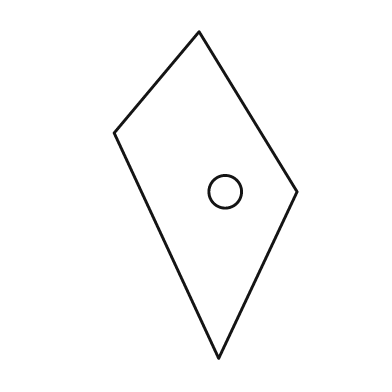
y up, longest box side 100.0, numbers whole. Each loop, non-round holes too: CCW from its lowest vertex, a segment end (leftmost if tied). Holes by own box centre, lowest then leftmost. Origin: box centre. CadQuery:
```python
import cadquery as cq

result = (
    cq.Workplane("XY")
    .moveTo(4.0, -50.0)
    .lineTo(28.0, 1.0)
    .lineTo(-2.0, 50.0)
    .lineTo(-28.0, 19.0)
    .close()
    .moveTo(6.0, 1.0)
    .circle(5.0)
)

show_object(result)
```